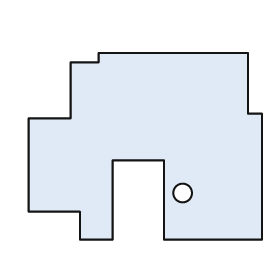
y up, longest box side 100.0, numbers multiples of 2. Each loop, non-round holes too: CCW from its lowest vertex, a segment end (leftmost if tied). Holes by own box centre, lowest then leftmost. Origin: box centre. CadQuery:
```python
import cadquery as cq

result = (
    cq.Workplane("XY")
    .moveTo(-28.0, -40.0)
    .lineTo(-14.0, -40.0)
    .lineTo(-14.0, -6.0)
    .lineTo(8.0, -6.0)
    .lineTo(8.0, -40.0)
    .lineTo(50.0, -40.0)
    .lineTo(50.0, 14.0)
    .lineTo(44.0, 14.0)
    .lineTo(44.0, 40.0)
    .lineTo(-20.0, 40.0)
    .lineTo(-20.0, 36.0)
    .lineTo(-32.0, 36.0)
    .lineTo(-32.0, 12.0)
    .lineTo(-50.0, 12.0)
    .lineTo(-50.0, -28.0)
    .lineTo(-28.0, -28.0)
    .close()
    .moveTo(16.0, -20.0)
    .circle(4.0)
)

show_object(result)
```